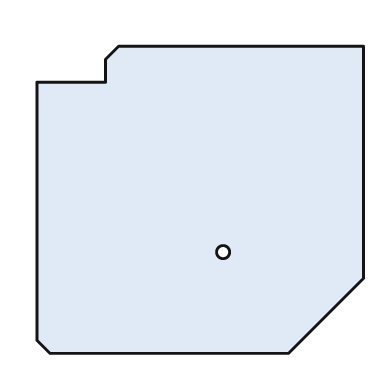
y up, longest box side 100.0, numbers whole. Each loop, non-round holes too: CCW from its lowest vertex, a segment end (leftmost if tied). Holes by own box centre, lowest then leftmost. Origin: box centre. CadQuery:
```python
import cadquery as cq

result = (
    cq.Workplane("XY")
    .moveTo(-46.0, -47.0)
    .lineTo(27.0, -47.0)
    .lineTo(50.0, -24.0)
    .lineTo(50.0, 47.0)
    .lineTo(-25.0, 47.0)
    .lineTo(-29.0, 43.0)
    .lineTo(-29.0, 36.0)
    .lineTo(-50.0, 36.0)
    .lineTo(-50.0, -43.0)
    .close()
    .moveTo(7.0, -16.0)
    .circle(2.0)
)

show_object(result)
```